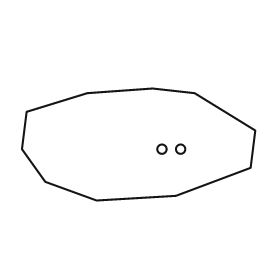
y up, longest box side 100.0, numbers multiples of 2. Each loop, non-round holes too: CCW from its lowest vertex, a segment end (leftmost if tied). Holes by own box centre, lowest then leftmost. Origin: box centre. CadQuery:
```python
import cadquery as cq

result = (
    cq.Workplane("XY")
    .moveTo(-18.0, -24.0)
    .lineTo(16.0, -22.0)
    .lineTo(48.0, -10.0)
    .lineTo(50.0, 6.0)
    .lineTo(24.0, 22.0)
    .lineTo(6.0, 24.0)
    .lineTo(-22.0, 22.0)
    .lineTo(-48.0, 14.0)
    .lineTo(-50.0, -2.0)
    .lineTo(-40.0, -16.0)
    .close()
    .moveTo(10.0, -2.0)
    .circle(2.0)
    .moveTo(18.0, -2.0)
    .circle(2.0)
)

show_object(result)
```